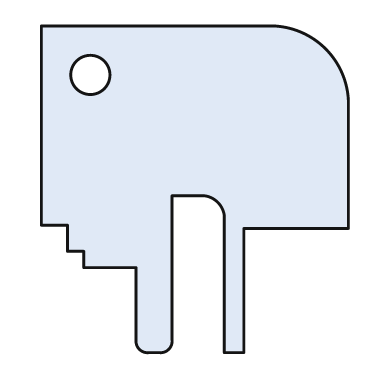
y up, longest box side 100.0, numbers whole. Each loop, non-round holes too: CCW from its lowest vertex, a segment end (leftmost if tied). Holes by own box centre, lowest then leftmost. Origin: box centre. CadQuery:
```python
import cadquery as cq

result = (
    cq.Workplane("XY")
    .moveTo(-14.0, -50.0)
    .lineTo(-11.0, -50.0)
    .threePointArc((-8.0, -49.0), (-7.0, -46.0))
    .lineTo(-7.0, -2.0)
    .lineTo(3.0, -2.0)
    .threePointArc((7.0, -4.0), (9.0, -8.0))
    .lineTo(9.0, -50.0)
    .lineTo(15.0, -50.0)
    .lineTo(15.0, -12.0)
    .lineTo(47.0, -12.0)
    .lineTo(47.0, 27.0)
    .threePointArc((40.0, 43.0), (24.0, 50.0))
    .lineTo(-47.0, 50.0)
    .lineTo(-47.0, -11.0)
    .lineTo(-39.0, -11.0)
    .lineTo(-39.0, -19.0)
    .lineTo(-34.0, -19.0)
    .lineTo(-34.0, -24.0)
    .lineTo(-18.0, -24.0)
    .lineTo(-18.0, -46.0)
    .threePointArc((-17.0, -49.0), (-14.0, -50.0))
    .close()
    .moveTo(-32.0, 35.0)
    .circle(6.0)
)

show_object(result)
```